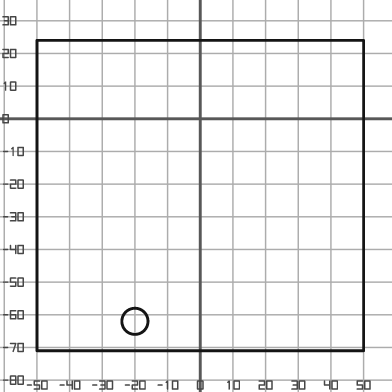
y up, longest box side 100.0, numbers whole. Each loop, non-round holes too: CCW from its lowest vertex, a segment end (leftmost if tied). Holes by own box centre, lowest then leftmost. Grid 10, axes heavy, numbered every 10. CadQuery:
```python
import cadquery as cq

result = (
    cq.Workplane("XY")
    .moveTo(-50.0, -71.0)
    .lineTo(50.0, -71.0)
    .lineTo(50.0, 24.0)
    .lineTo(-50.0, 24.0)
    .close()
    .moveTo(-20.0, -62.0)
    .circle(4.0)
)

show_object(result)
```